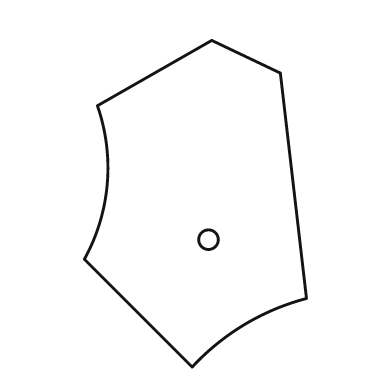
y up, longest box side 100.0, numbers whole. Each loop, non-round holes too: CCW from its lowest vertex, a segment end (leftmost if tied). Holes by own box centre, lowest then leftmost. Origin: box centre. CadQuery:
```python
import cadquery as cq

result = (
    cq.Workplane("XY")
    .moveTo(-1.0, -50.0)
    .threePointArc((15.0, -37.0), (34.0, -29.0))
    .lineTo(26.0, 40.0)
    .lineTo(5.0, 50.0)
    .lineTo(-30.0, 30.0)
    .threePointArc((-27.0, 6.0), (-34.0, -17.0))
    .close()
    .moveTo(4.0, -11.0)
    .circle(3.0)
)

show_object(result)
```